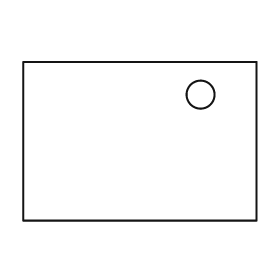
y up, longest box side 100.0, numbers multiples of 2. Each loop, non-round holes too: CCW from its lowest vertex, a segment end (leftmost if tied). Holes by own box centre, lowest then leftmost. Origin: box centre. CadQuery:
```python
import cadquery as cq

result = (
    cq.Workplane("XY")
    .moveTo(-50.0, -34.0)
    .lineTo(50.0, -34.0)
    .lineTo(50.0, 34.0)
    .lineTo(-50.0, 34.0)
    .close()
    .moveTo(26.0, 20.0)
    .circle(6.0)
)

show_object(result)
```